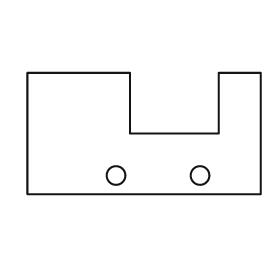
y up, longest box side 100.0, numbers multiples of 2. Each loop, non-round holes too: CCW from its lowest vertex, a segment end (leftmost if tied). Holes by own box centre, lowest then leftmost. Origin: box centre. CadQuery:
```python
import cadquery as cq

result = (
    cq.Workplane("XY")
    .moveTo(-50.0, -26.0)
    .lineTo(50.0, -26.0)
    .lineTo(50.0, 26.0)
    .lineTo(32.0, 26.0)
    .lineTo(32.0, 0.0)
    .lineTo(-6.0, 0.0)
    .lineTo(-6.0, 26.0)
    .lineTo(-50.0, 26.0)
    .close()
    .moveTo(-12.0, -18.0)
    .circle(4.0)
    .moveTo(24.0, -18.0)
    .circle(4.0)
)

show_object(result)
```